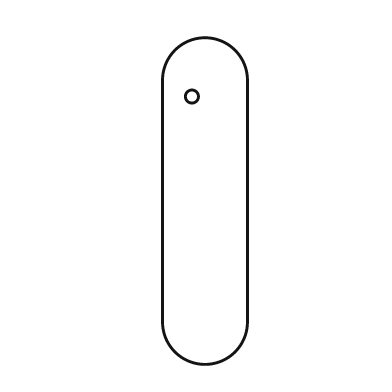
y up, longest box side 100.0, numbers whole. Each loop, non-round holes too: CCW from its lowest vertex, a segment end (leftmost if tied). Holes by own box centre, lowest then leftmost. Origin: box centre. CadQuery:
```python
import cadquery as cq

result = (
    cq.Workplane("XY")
    .moveTo(-13.0, -37.0)
    .threePointArc((0.0, -50.0), (13.0, -37.0))
    .lineTo(13.0, 37.0)
    .threePointArc((0.0, 50.0), (-13.0, 37.0))
    .close()
    .moveTo(-4.0, 32.0)
    .circle(2.0)
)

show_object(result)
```